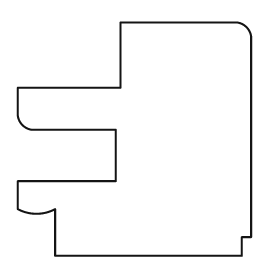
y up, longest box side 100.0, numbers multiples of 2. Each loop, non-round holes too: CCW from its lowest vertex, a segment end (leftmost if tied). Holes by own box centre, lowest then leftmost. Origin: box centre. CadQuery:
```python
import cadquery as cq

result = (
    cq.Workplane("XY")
    .moveTo(-34.0, -50.0)
    .lineTo(46.0, -50.0)
    .lineTo(46.0, -42.0)
    .lineTo(50.0, -42.0)
    .lineTo(50.0, 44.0)
    .threePointArc((48.0, 48.0), (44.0, 50.0))
    .lineTo(-6.0, 50.0)
    .lineTo(-6.0, 22.0)
    .lineTo(-50.0, 22.0)
    .lineTo(-50.0, 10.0)
    .threePointArc((-48.0, 6.0), (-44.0, 4.0))
    .lineTo(-8.0, 4.0)
    .lineTo(-8.0, -18.0)
    .lineTo(-50.0, -18.0)
    .lineTo(-50.0, -30.0)
    .threePointArc((-42.0, -32.0), (-34.0, -30.0))
    .close()
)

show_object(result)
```